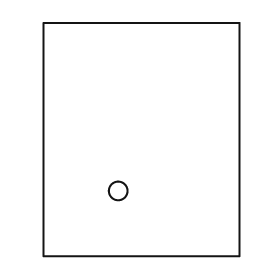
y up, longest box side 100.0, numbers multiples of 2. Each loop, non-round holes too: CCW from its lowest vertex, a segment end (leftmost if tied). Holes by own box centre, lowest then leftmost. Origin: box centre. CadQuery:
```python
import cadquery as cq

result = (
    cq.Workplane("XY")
    .moveTo(-42.0, -50.0)
    .lineTo(42.0, -50.0)
    .lineTo(42.0, 50.0)
    .lineTo(-42.0, 50.0)
    .close()
    .moveTo(-10.0, -22.0)
    .circle(4.0)
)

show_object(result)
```